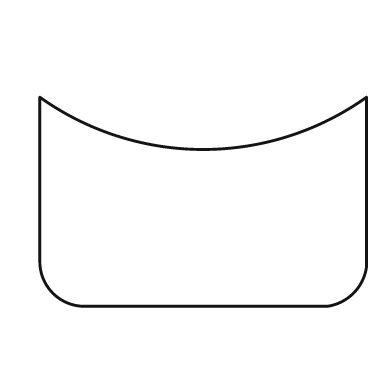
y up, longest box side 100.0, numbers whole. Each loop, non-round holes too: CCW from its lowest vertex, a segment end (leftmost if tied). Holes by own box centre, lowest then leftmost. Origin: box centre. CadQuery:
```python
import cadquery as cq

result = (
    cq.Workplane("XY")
    .moveTo(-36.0, -32.0)
    .lineTo(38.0, -32.0)
    .threePointArc((46.0, -28.0), (50.0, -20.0))
    .lineTo(50.0, 32.0)
    .threePointArc((0.0, 16.0), (-50.0, 32.0))
    .lineTo(-50.0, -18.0)
    .threePointArc((-46.0, -28.0), (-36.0, -32.0))
    .close()
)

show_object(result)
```